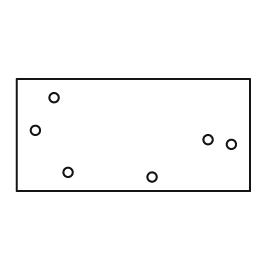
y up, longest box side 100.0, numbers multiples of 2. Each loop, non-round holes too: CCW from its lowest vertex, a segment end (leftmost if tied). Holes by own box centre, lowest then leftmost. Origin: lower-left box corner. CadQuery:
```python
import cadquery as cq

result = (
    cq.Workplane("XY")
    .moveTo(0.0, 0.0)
    .lineTo(100.0, 0.0)
    .lineTo(100.0, 48.0)
    .lineTo(0.0, 48.0)
    .close()
    .moveTo(58.0, 6.0)
    .circle(2.0)
    .moveTo(22.0, 8.0)
    .circle(2.0)
    .moveTo(92.0, 20.0)
    .circle(2.0)
    .moveTo(82.0, 22.0)
    .circle(2.0)
    .moveTo(8.0, 26.0)
    .circle(2.0)
    .moveTo(16.0, 40.0)
    .circle(2.0)
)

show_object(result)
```